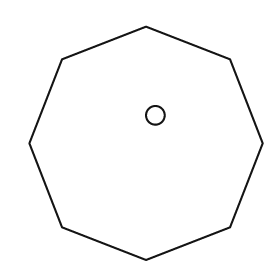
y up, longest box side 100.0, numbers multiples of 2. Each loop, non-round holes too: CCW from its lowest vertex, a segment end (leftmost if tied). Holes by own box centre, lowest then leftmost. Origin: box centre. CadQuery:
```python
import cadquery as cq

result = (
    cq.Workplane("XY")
    .moveTo(0.0, -50.0)
    .lineTo(36.0, -36.0)
    .lineTo(50.0, 0.0)
    .lineTo(36.0, 36.0)
    .lineTo(0.0, 50.0)
    .lineTo(-36.0, 36.0)
    .lineTo(-50.0, 0.0)
    .lineTo(-36.0, -36.0)
    .close()
    .moveTo(4.0, 12.0)
    .circle(4.0)
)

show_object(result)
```